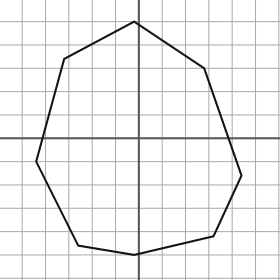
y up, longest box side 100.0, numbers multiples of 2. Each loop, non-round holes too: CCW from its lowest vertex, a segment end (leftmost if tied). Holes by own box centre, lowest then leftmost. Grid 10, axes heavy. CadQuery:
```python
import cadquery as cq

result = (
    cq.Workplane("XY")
    .moveTo(-2.0, -50.0)
    .lineTo(32.0, -42.0)
    .lineTo(44.0, -16.0)
    .lineTo(28.0, 30.0)
    .lineTo(-2.0, 50.0)
    .lineTo(-32.0, 34.0)
    .lineTo(-44.0, -10.0)
    .lineTo(-26.0, -46.0)
    .close()
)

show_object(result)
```